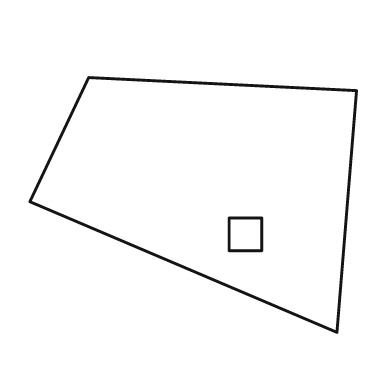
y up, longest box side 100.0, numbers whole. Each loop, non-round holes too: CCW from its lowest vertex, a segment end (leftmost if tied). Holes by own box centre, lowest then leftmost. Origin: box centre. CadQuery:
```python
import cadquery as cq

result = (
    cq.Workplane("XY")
    .moveTo(44.0, -39.0)
    .lineTo(50.0, 35.0)
    .lineTo(-32.0, 39.0)
    .lineTo(-50.0, 1.0)
    .close()
    .moveTo(11.0, -14.0)
    .lineTo(21.0, -14.0)
    .lineTo(21.0, -4.0)
    .lineTo(11.0, -4.0)
    .close()
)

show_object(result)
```